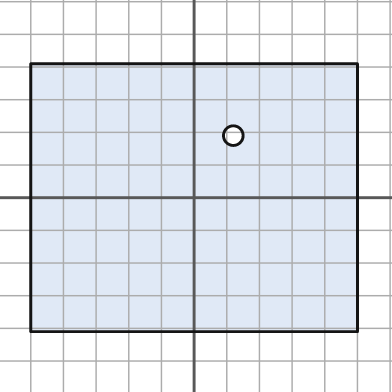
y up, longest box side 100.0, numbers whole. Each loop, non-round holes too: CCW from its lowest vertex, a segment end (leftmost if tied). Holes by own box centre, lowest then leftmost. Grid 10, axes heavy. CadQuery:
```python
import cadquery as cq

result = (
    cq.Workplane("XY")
    .moveTo(-50.0, -41.0)
    .lineTo(50.0, -41.0)
    .lineTo(50.0, 41.0)
    .lineTo(-50.0, 41.0)
    .close()
    .moveTo(12.0, 19.0)
    .circle(3.0)
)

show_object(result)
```